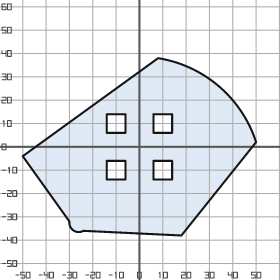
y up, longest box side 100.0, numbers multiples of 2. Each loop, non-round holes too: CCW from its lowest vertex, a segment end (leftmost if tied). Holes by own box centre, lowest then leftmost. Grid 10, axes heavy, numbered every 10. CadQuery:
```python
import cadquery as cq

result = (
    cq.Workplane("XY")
    .moveTo(18.0, -38.0)
    .lineTo(50.0, 2.0)
    .threePointArc((34.0, 26.0), (8.0, 38.0))
    .lineTo(-50.0, -4.0)
    .lineTo(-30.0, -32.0)
    .threePointArc((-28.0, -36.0), (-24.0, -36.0))
    .close()
    .moveTo(-14.0, -14.0)
    .lineTo(-6.0, -14.0)
    .lineTo(-6.0, -6.0)
    .lineTo(-14.0, -6.0)
    .close()
    .moveTo(6.0, -14.0)
    .lineTo(14.0, -14.0)
    .lineTo(14.0, -6.0)
    .lineTo(6.0, -6.0)
    .close()
    .moveTo(-14.0, 6.0)
    .lineTo(-6.0, 6.0)
    .lineTo(-6.0, 14.0)
    .lineTo(-14.0, 14.0)
    .close()
    .moveTo(6.0, 6.0)
    .lineTo(14.0, 6.0)
    .lineTo(14.0, 14.0)
    .lineTo(6.0, 14.0)
    .close()
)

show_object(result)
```